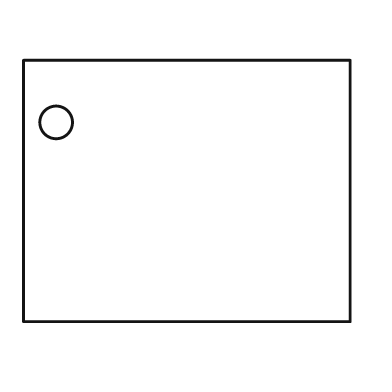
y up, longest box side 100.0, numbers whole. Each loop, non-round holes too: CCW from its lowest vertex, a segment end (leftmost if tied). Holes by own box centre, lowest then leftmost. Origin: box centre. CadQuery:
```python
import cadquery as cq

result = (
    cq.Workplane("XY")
    .moveTo(-50.0, -40.0)
    .lineTo(50.0, -40.0)
    .lineTo(50.0, 40.0)
    .lineTo(-50.0, 40.0)
    .close()
    .moveTo(-40.0, 21.0)
    .circle(5.0)
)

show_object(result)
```